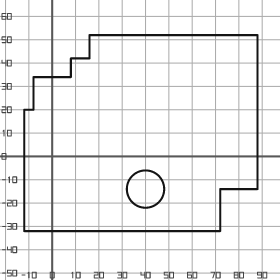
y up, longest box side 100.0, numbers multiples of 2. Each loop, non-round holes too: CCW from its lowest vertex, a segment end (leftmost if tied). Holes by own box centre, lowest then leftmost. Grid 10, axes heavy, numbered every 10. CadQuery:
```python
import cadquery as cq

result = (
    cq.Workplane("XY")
    .moveTo(-12.0, -32.0)
    .lineTo(72.0, -32.0)
    .lineTo(72.0, -14.0)
    .lineTo(88.0, -14.0)
    .lineTo(88.0, 52.0)
    .lineTo(16.0, 52.0)
    .lineTo(16.0, 42.0)
    .lineTo(8.0, 42.0)
    .lineTo(8.0, 34.0)
    .lineTo(-8.0, 34.0)
    .lineTo(-8.0, 20.0)
    .lineTo(-12.0, 20.0)
    .close()
    .moveTo(40.0, -14.0)
    .circle(8.0)
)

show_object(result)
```